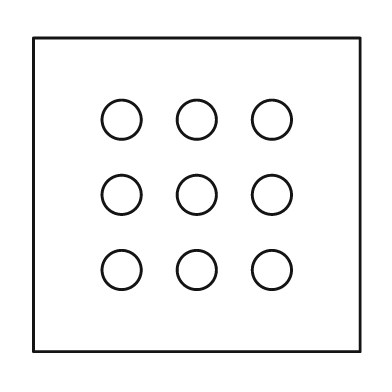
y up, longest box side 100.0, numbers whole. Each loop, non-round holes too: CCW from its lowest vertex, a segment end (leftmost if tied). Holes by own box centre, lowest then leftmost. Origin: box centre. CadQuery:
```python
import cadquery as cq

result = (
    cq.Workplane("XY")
    .moveTo(-50.0, -48.0)
    .lineTo(50.0, -48.0)
    .lineTo(50.0, 48.0)
    .lineTo(-50.0, 48.0)
    .close()
    .moveTo(-23.0, -23.0)
    .circle(6.0)
    .moveTo(0.0, -23.0)
    .circle(6.0)
    .moveTo(23.0, -23.0)
    .circle(6.0)
    .moveTo(-23.0, 0.0)
    .circle(6.0)
    .moveTo(0.0, 0.0)
    .circle(6.0)
    .moveTo(23.0, 0.0)
    .circle(6.0)
    .moveTo(-23.0, 23.0)
    .circle(6.0)
    .moveTo(0.0, 23.0)
    .circle(6.0)
    .moveTo(23.0, 23.0)
    .circle(6.0)
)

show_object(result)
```